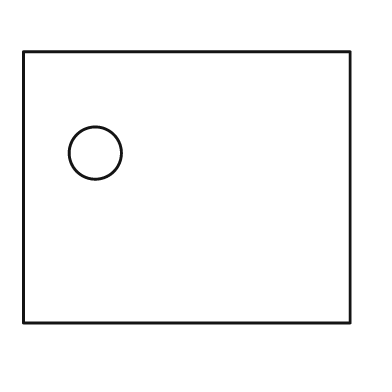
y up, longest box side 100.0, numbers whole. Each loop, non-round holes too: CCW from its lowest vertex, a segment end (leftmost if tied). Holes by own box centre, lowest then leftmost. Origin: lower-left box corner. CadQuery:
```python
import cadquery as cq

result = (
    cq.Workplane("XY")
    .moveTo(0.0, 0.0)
    .lineTo(100.0, 0.0)
    .lineTo(100.0, 83.0)
    .lineTo(0.0, 83.0)
    .close()
    .moveTo(22.0, 52.0)
    .circle(8.0)
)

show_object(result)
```